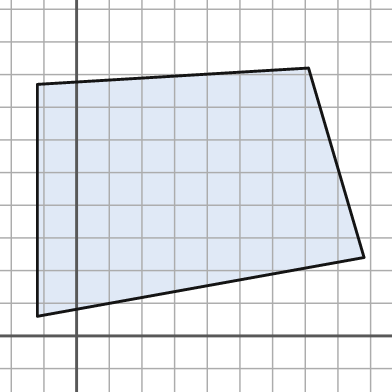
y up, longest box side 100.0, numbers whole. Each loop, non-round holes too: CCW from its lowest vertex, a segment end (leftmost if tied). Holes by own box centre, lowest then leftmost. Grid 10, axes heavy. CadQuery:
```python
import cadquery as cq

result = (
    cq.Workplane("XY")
    .moveTo(-12.0, 6.0)
    .lineTo(88.0, 24.0)
    .lineTo(71.0, 82.0)
    .lineTo(-12.0, 77.0)
    .close()
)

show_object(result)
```